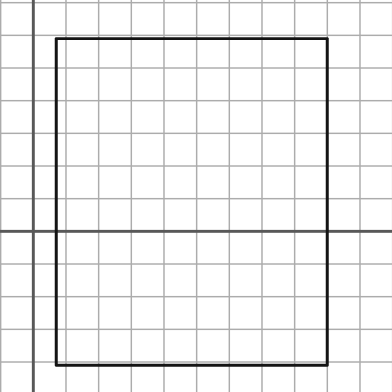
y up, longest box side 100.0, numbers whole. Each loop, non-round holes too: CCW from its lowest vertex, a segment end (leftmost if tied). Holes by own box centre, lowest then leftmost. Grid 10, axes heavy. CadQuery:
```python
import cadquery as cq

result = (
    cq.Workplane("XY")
    .moveTo(7.0, -41.0)
    .lineTo(90.0, -41.0)
    .lineTo(90.0, 59.0)
    .lineTo(7.0, 59.0)
    .close()
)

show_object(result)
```